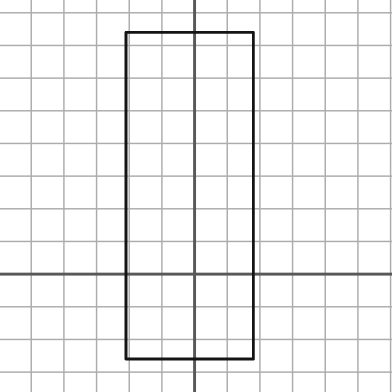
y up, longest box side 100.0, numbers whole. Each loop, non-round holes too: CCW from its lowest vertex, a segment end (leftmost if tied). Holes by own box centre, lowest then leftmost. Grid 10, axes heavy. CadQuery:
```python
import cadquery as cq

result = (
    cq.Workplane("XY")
    .moveTo(-21.0, -26.0)
    .lineTo(18.0, -26.0)
    .lineTo(18.0, 74.0)
    .lineTo(-21.0, 74.0)
    .close()
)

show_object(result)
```